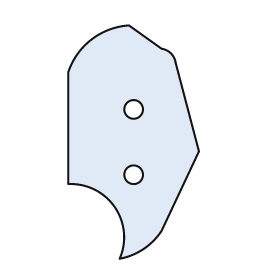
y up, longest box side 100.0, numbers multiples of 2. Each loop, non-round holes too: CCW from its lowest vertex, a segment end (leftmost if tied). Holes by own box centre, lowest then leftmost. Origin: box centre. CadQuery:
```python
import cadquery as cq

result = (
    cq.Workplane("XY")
    .moveTo(-6.0, -50.0)
    .threePointArc((4.0, -46.0), (12.0, -38.0))
    .lineTo(28.0, -4.0)
    .lineTo(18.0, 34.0)
    .threePointArc((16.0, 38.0), (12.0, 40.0))
    .lineTo(-2.0, 50.0)
    .threePointArc((-18.0, 44.0), (-28.0, 30.0))
    .lineTo(-28.0, -18.0)
    .threePointArc((-8.0, -28.0), (-6.0, -50.0))
    .close()
    .moveTo(0.0, -14.0)
    .circle(4.0)
    .moveTo(0.0, 14.0)
    .circle(4.0)
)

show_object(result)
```